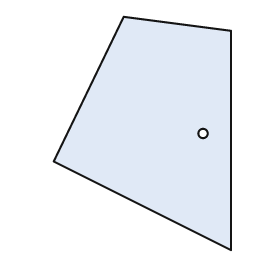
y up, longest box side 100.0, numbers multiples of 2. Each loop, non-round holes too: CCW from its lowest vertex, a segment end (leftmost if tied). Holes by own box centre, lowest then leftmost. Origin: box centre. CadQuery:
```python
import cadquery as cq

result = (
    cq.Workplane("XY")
    .moveTo(38.0, -50.0)
    .lineTo(38.0, 44.0)
    .lineTo(-8.0, 50.0)
    .lineTo(-38.0, -12.0)
    .close()
    .moveTo(26.0, 0.0)
    .circle(2.0)
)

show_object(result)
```